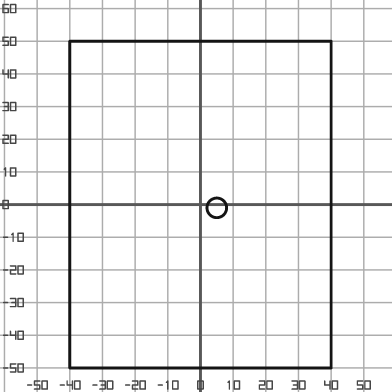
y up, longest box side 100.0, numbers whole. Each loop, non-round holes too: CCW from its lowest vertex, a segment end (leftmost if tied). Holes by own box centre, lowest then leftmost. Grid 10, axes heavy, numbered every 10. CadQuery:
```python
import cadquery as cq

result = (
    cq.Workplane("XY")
    .moveTo(-40.0, -50.0)
    .lineTo(40.0, -50.0)
    .lineTo(40.0, 50.0)
    .lineTo(-40.0, 50.0)
    .close()
    .moveTo(5.0, -1.0)
    .circle(3.0)
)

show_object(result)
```